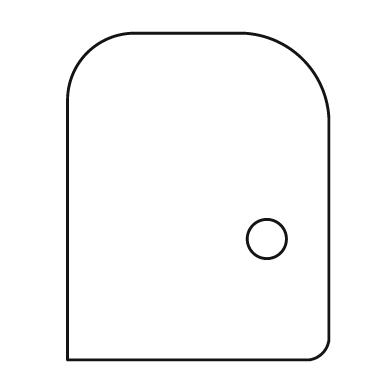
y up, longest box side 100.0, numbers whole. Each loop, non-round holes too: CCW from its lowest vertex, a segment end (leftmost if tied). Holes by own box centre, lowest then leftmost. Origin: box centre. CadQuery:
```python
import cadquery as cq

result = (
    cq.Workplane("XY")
    .moveTo(-40.0, -50.0)
    .lineTo(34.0, -50.0)
    .threePointArc((38.0, -48.0), (40.0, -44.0))
    .lineTo(40.0, 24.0)
    .threePointArc((32.0, 42.0), (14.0, 50.0))
    .lineTo(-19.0, 50.0)
    .threePointArc((-34.0, 44.0), (-40.0, 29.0))
    .close()
    .moveTo(21.0, -13.0)
    .circle(6.0)
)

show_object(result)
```